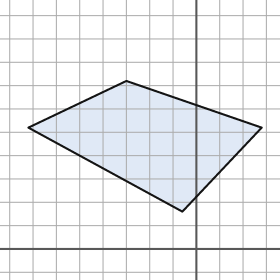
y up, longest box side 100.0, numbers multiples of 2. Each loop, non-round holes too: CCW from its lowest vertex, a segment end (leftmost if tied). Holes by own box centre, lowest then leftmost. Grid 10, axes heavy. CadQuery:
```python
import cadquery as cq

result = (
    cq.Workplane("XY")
    .moveTo(-6.0, 16.0)
    .lineTo(28.0, 52.0)
    .lineTo(-30.0, 72.0)
    .lineTo(-72.0, 52.0)
    .close()
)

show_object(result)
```